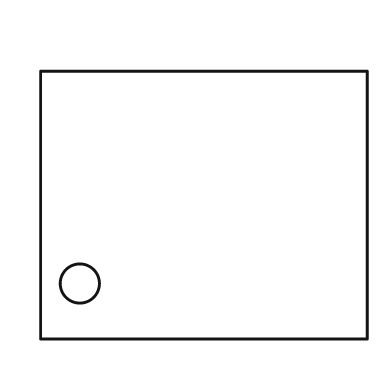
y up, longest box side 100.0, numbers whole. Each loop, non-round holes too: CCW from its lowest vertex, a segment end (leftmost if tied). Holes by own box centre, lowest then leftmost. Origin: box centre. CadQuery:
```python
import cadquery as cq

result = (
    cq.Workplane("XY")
    .moveTo(-50.0, -41.0)
    .lineTo(50.0, -41.0)
    .lineTo(50.0, 41.0)
    .lineTo(-50.0, 41.0)
    .close()
    .moveTo(-38.0, -24.0)
    .circle(6.0)
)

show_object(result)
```